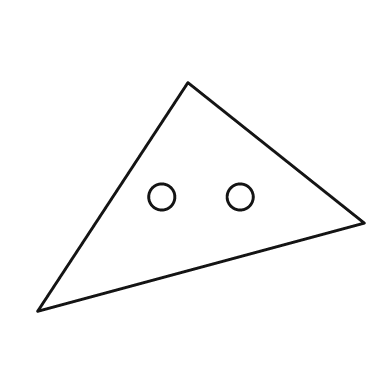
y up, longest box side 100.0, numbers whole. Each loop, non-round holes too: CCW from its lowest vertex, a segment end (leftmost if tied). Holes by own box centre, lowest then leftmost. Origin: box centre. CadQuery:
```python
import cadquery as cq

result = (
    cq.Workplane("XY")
    .moveTo(-50.0, -35.0)
    .lineTo(50.0, -8.0)
    .lineTo(-4.0, 35.0)
    .close()
    .moveTo(-12.0, 0.0)
    .circle(4.0)
    .moveTo(12.0, 0.0)
    .circle(4.0)
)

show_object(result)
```